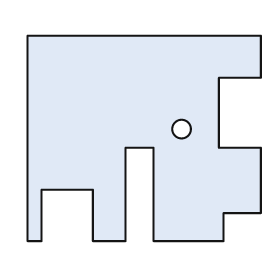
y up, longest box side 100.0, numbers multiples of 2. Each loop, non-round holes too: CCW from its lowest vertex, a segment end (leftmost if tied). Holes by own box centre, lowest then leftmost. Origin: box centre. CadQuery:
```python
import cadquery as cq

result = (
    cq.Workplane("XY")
    .moveTo(-50.0, -44.0)
    .lineTo(-44.0, -44.0)
    .lineTo(-44.0, -22.0)
    .lineTo(-22.0, -22.0)
    .lineTo(-22.0, -44.0)
    .lineTo(-8.0, -44.0)
    .lineTo(-8.0, -4.0)
    .lineTo(4.0, -4.0)
    .lineTo(4.0, -44.0)
    .lineTo(34.0, -44.0)
    .lineTo(34.0, -32.0)
    .lineTo(50.0, -32.0)
    .lineTo(50.0, -4.0)
    .lineTo(32.0, -4.0)
    .lineTo(32.0, 26.0)
    .lineTo(50.0, 26.0)
    .lineTo(50.0, 44.0)
    .lineTo(-50.0, 44.0)
    .close()
    .moveTo(16.0, 4.0)
    .circle(4.0)
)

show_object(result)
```